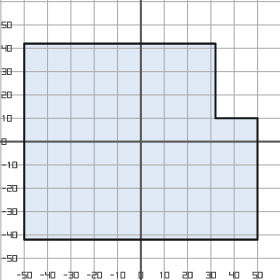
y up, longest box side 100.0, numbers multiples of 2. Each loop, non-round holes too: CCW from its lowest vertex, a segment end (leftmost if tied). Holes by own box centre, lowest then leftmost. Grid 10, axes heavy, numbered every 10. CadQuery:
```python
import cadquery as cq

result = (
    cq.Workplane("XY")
    .moveTo(-50.0, -42.0)
    .lineTo(50.0, -42.0)
    .lineTo(50.0, 10.0)
    .lineTo(32.0, 10.0)
    .lineTo(32.0, 42.0)
    .lineTo(-50.0, 42.0)
    .close()
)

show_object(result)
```